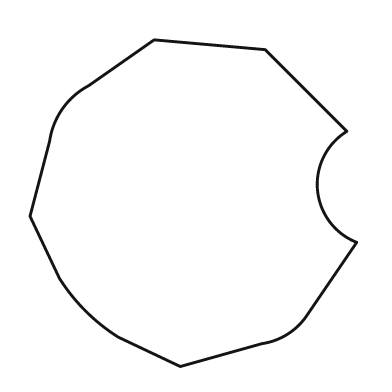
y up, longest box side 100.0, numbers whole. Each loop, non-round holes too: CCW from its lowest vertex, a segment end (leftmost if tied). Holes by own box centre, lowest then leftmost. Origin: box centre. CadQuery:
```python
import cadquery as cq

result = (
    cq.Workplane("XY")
    .moveTo(-4.0, -50.0)
    .lineTo(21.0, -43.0)
    .threePointArc((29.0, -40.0), (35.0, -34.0))
    .lineTo(50.0, -12.0)
    .threePointArc((38.0, 4.0), (47.0, 22.0))
    .lineTo(22.0, 47.0)
    .lineTo(-12.0, 50.0)
    .lineTo(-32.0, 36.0)
    .threePointArc((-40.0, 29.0), (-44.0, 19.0))
    .lineTo(-50.0, -4.0)
    .lineTo(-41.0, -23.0)
    .threePointArc((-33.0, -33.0), (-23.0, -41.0))
    .close()
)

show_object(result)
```